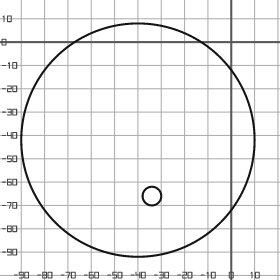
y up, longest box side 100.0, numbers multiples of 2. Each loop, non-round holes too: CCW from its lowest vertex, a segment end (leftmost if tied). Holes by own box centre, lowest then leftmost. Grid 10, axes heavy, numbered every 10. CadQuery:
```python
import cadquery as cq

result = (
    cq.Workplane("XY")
    .moveTo(-40.0, -42.0)
    .circle(50.0)
    .moveTo(-34.0, -66.0)
    .circle(4.0)
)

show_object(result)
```